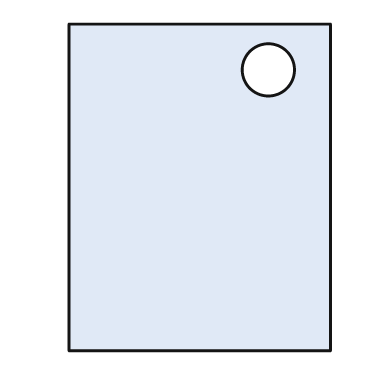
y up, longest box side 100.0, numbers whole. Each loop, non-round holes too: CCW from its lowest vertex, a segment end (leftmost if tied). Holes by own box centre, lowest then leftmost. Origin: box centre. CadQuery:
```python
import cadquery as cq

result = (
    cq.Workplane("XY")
    .moveTo(-40.0, -50.0)
    .lineTo(40.0, -50.0)
    .lineTo(40.0, 50.0)
    .lineTo(-40.0, 50.0)
    .close()
    .moveTo(21.0, 36.0)
    .circle(8.0)
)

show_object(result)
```